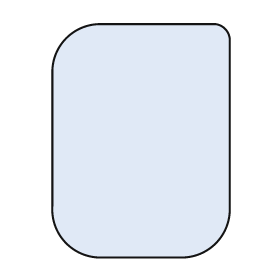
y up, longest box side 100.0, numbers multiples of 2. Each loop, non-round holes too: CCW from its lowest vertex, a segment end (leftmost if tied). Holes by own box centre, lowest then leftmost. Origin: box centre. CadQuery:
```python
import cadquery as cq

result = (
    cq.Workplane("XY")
    .moveTo(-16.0, -50.0)
    .lineTo(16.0, -50.0)
    .threePointArc((32.0, -44.0), (38.0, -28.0))
    .lineTo(38.0, 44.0)
    .threePointArc((36.0, 48.0), (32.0, 50.0))
    .lineTo(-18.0, 50.0)
    .threePointArc((-32.0, 44.0), (-38.0, 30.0))
    .lineTo(-38.0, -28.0)
    .threePointArc((-32.0, -44.0), (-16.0, -50.0))
    .close()
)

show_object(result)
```